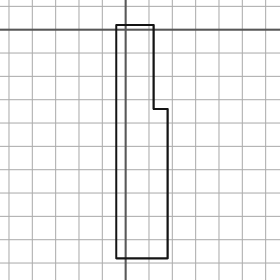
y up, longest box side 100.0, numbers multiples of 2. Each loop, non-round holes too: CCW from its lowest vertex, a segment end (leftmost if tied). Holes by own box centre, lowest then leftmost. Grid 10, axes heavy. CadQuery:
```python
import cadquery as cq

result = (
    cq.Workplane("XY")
    .moveTo(-4.0, -98.0)
    .lineTo(18.0, -98.0)
    .lineTo(18.0, -34.0)
    .lineTo(12.0, -34.0)
    .lineTo(12.0, 2.0)
    .lineTo(-4.0, 2.0)
    .close()
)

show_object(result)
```